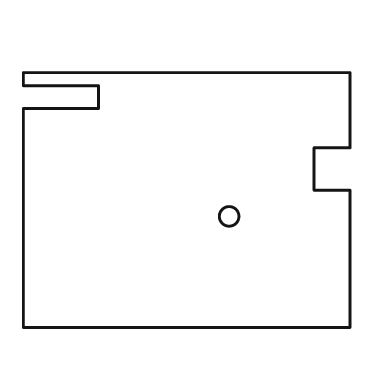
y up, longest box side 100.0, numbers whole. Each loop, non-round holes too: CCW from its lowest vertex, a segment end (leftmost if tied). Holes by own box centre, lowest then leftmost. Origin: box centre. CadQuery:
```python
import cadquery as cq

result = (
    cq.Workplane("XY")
    .moveTo(-50.0, -39.0)
    .lineTo(50.0, -39.0)
    .lineTo(50.0, 3.0)
    .lineTo(39.0, 3.0)
    .lineTo(39.0, 16.0)
    .lineTo(50.0, 16.0)
    .lineTo(50.0, 39.0)
    .lineTo(-50.0, 39.0)
    .lineTo(-50.0, 35.0)
    .lineTo(-27.0, 35.0)
    .lineTo(-27.0, 28.0)
    .lineTo(-50.0, 28.0)
    .close()
    .moveTo(13.0, -5.0)
    .circle(3.0)
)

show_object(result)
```